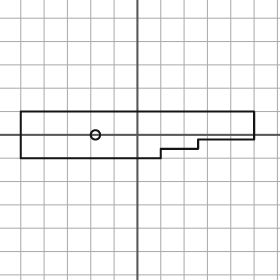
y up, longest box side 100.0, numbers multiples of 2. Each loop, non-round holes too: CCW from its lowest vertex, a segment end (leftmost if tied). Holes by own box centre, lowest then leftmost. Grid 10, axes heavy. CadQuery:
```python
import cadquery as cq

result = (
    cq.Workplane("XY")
    .moveTo(-50.0, -10.0)
    .lineTo(10.0, -10.0)
    .lineTo(10.0, -6.0)
    .lineTo(26.0, -6.0)
    .lineTo(26.0, -2.0)
    .lineTo(50.0, -2.0)
    .lineTo(50.0, 10.0)
    .lineTo(-50.0, 10.0)
    .close()
    .moveTo(-18.0, 0.0)
    .circle(2.0)
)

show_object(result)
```